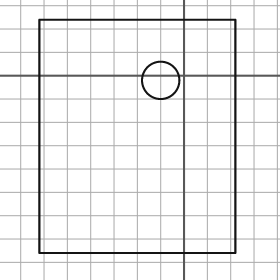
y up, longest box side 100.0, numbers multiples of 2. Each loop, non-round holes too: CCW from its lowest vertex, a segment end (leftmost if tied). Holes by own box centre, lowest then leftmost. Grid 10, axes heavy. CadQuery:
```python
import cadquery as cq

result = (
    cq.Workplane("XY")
    .moveTo(-62.0, -76.0)
    .lineTo(22.0, -76.0)
    .lineTo(22.0, 24.0)
    .lineTo(-62.0, 24.0)
    .close()
    .moveTo(-10.0, -2.0)
    .circle(8.0)
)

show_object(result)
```